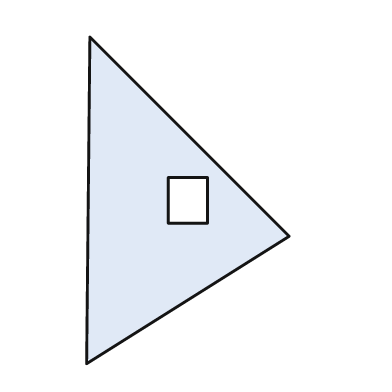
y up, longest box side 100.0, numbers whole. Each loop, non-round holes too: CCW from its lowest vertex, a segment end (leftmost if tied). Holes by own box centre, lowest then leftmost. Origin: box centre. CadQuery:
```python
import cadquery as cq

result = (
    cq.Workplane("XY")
    .moveTo(-31.0, -50.0)
    .lineTo(31.0, -11.0)
    .lineTo(-30.0, 50.0)
    .close()
    .moveTo(-6.0, -7.0)
    .lineTo(6.0, -7.0)
    .lineTo(6.0, 7.0)
    .lineTo(-6.0, 7.0)
    .close()
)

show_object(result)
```